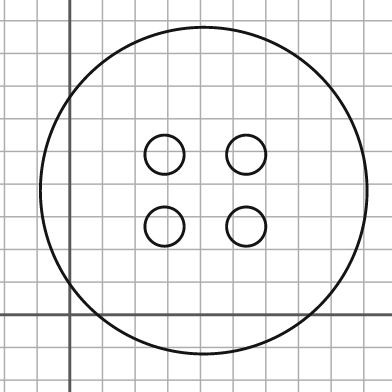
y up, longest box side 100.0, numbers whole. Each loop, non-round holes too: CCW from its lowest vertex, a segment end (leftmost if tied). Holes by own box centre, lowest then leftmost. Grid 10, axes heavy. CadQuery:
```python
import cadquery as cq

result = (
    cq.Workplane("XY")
    .moveTo(41.0, 38.0)
    .circle(50.0)
    .moveTo(29.0, 27.0)
    .circle(6.0)
    .moveTo(54.0, 27.0)
    .circle(6.0)
    .moveTo(29.0, 49.0)
    .circle(6.0)
    .moveTo(54.0, 49.0)
    .circle(6.0)
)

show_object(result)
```